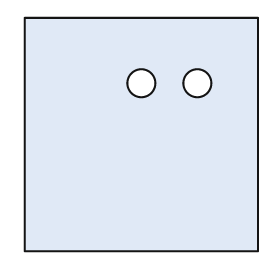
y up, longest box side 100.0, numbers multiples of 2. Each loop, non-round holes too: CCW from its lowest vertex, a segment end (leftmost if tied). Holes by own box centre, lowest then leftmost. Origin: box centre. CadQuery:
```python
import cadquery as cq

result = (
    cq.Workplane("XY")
    .moveTo(-50.0, -50.0)
    .lineTo(50.0, -50.0)
    .lineTo(50.0, 50.0)
    .lineTo(-50.0, 50.0)
    .close()
    .moveTo(0.0, 22.0)
    .circle(6.0)
    .moveTo(24.0, 22.0)
    .circle(6.0)
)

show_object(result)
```